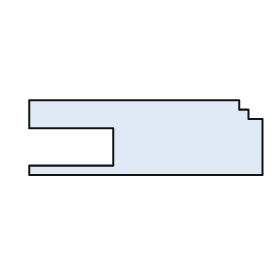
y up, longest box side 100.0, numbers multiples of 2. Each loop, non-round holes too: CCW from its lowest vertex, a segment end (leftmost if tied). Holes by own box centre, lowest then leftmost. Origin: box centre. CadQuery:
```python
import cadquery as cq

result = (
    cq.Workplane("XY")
    .moveTo(-50.0, -16.0)
    .lineTo(50.0, -16.0)
    .lineTo(50.0, 8.0)
    .lineTo(44.0, 8.0)
    .lineTo(44.0, 12.0)
    .lineTo(40.0, 12.0)
    .lineTo(40.0, 16.0)
    .lineTo(-50.0, 16.0)
    .lineTo(-50.0, 4.0)
    .lineTo(-14.0, 4.0)
    .lineTo(-14.0, -12.0)
    .lineTo(-50.0, -12.0)
    .close()
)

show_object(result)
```